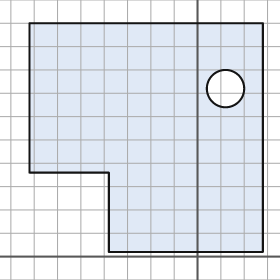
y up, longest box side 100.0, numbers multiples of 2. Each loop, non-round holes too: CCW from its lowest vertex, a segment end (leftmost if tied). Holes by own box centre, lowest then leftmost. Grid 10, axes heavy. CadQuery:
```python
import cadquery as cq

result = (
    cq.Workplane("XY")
    .moveTo(-38.0, 2.0)
    .lineTo(28.0, 2.0)
    .lineTo(28.0, 100.0)
    .lineTo(-72.0, 100.0)
    .lineTo(-72.0, 36.0)
    .lineTo(-38.0, 36.0)
    .close()
    .moveTo(12.0, 72.0)
    .circle(8.0)
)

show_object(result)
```